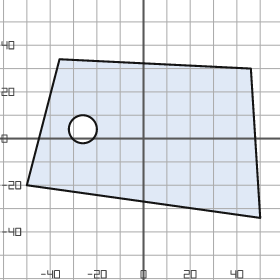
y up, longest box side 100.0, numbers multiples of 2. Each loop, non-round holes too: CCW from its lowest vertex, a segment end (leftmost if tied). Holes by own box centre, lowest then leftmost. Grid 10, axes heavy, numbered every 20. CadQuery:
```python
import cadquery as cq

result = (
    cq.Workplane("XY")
    .moveTo(50.0, -34.0)
    .lineTo(46.0, 30.0)
    .lineTo(-36.0, 34.0)
    .lineTo(-50.0, -20.0)
    .close()
    .moveTo(-26.0, 4.0)
    .circle(6.0)
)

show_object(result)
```